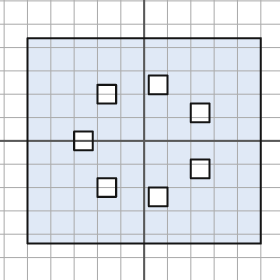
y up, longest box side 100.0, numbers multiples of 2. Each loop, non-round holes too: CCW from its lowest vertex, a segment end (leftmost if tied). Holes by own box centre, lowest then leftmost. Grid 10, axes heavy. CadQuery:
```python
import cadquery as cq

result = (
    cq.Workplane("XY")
    .moveTo(-50.0, -44.0)
    .lineTo(50.0, -44.0)
    .lineTo(50.0, 44.0)
    .lineTo(-50.0, 44.0)
    .close()
    .moveTo(2.0, -28.0)
    .lineTo(10.0, -28.0)
    .lineTo(10.0, -20.0)
    .lineTo(2.0, -20.0)
    .close()
    .moveTo(-20.0, -24.0)
    .lineTo(-12.0, -24.0)
    .lineTo(-12.0, -16.0)
    .lineTo(-20.0, -16.0)
    .close()
    .moveTo(20.0, -16.0)
    .lineTo(28.0, -16.0)
    .lineTo(28.0, -8.0)
    .lineTo(20.0, -8.0)
    .close()
    .moveTo(-30.0, -4.0)
    .lineTo(-22.0, -4.0)
    .lineTo(-22.0, 4.0)
    .lineTo(-30.0, 4.0)
    .close()
    .moveTo(20.0, 8.0)
    .lineTo(28.0, 8.0)
    .lineTo(28.0, 16.0)
    .lineTo(20.0, 16.0)
    .close()
    .moveTo(-20.0, 16.0)
    .lineTo(-12.0, 16.0)
    .lineTo(-12.0, 24.0)
    .lineTo(-20.0, 24.0)
    .close()
    .moveTo(2.0, 20.0)
    .lineTo(10.0, 20.0)
    .lineTo(10.0, 28.0)
    .lineTo(2.0, 28.0)
    .close()
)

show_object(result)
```